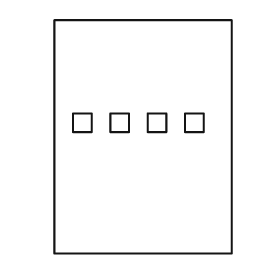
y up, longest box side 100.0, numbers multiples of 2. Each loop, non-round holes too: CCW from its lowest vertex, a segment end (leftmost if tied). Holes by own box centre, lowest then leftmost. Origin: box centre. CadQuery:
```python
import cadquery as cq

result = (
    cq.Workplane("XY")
    .moveTo(-38.0, -50.0)
    .lineTo(38.0, -50.0)
    .lineTo(38.0, 50.0)
    .lineTo(-38.0, 50.0)
    .close()
    .moveTo(-30.0, 2.0)
    .lineTo(-22.0, 2.0)
    .lineTo(-22.0, 10.0)
    .lineTo(-30.0, 10.0)
    .close()
    .moveTo(-14.0, 2.0)
    .lineTo(-6.0, 2.0)
    .lineTo(-6.0, 10.0)
    .lineTo(-14.0, 10.0)
    .close()
    .moveTo(2.0, 2.0)
    .lineTo(10.0, 2.0)
    .lineTo(10.0, 10.0)
    .lineTo(2.0, 10.0)
    .close()
    .moveTo(18.0, 2.0)
    .lineTo(26.0, 2.0)
    .lineTo(26.0, 10.0)
    .lineTo(18.0, 10.0)
    .close()
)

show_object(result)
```